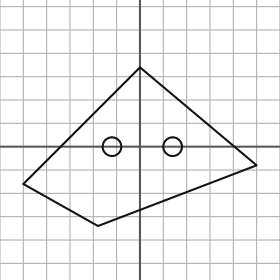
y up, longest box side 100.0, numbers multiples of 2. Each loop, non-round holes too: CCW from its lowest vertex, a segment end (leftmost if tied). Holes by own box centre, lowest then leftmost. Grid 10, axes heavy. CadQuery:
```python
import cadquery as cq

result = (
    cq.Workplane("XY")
    .moveTo(-18.0, -34.0)
    .lineTo(50.0, -8.0)
    .lineTo(0.0, 34.0)
    .lineTo(-50.0, -16.0)
    .close()
    .moveTo(-12.0, 0.0)
    .circle(4.0)
    .moveTo(14.0, 0.0)
    .circle(4.0)
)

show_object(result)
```